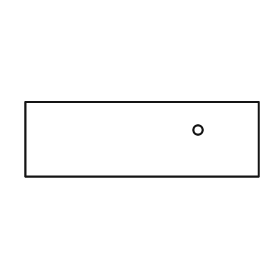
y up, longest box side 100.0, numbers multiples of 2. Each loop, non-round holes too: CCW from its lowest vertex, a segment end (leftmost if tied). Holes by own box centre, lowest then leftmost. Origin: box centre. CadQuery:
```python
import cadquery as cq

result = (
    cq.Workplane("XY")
    .moveTo(-50.0, -16.0)
    .lineTo(50.0, -16.0)
    .lineTo(50.0, 16.0)
    .lineTo(-50.0, 16.0)
    .close()
    .moveTo(24.0, 4.0)
    .circle(2.0)
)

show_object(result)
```